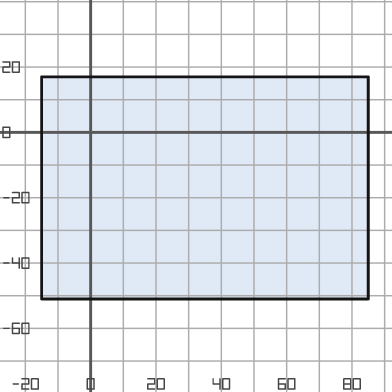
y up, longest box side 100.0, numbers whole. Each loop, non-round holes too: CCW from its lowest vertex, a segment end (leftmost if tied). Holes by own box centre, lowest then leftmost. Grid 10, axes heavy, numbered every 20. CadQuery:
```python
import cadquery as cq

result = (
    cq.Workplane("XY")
    .moveTo(-15.0, -51.0)
    .lineTo(85.0, -51.0)
    .lineTo(85.0, 17.0)
    .lineTo(-15.0, 17.0)
    .close()
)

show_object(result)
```